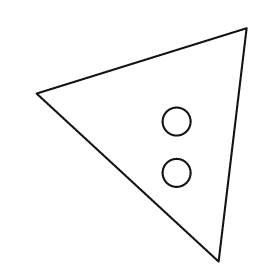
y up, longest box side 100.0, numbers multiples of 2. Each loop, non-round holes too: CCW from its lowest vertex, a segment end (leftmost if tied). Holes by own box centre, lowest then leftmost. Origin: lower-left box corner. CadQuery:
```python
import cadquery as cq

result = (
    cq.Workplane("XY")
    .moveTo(78.0, 0.0)
    .lineTo(90.0, 100.0)
    .lineTo(0.0, 72.0)
    .close()
    .moveTo(60.0, 38.0)
    .circle(6.0)
    .moveTo(60.0, 60.0)
    .circle(6.0)
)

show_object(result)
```